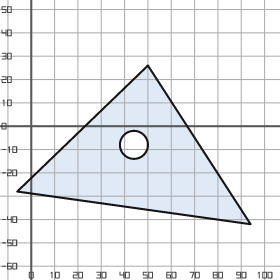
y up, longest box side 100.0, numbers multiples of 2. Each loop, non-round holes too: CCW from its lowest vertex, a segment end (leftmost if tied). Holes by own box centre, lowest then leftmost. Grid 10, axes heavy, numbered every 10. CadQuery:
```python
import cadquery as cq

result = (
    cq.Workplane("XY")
    .moveTo(94.0, -42.0)
    .lineTo(50.0, 26.0)
    .lineTo(-6.0, -28.0)
    .close()
    .moveTo(44.0, -8.0)
    .circle(6.0)
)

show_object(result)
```